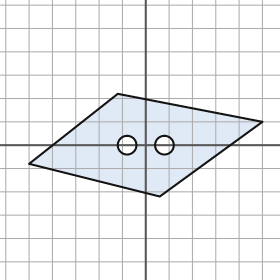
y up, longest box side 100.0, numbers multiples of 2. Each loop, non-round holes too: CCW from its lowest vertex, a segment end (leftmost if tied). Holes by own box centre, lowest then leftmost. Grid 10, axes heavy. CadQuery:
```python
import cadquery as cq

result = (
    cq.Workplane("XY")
    .moveTo(6.0, -22.0)
    .lineTo(50.0, 10.0)
    .lineTo(-12.0, 22.0)
    .lineTo(-50.0, -8.0)
    .close()
    .moveTo(-8.0, 0.0)
    .circle(4.0)
    .moveTo(8.0, 0.0)
    .circle(4.0)
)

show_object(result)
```